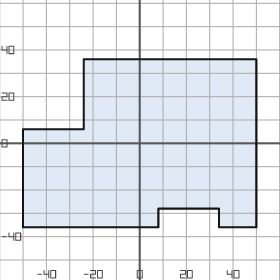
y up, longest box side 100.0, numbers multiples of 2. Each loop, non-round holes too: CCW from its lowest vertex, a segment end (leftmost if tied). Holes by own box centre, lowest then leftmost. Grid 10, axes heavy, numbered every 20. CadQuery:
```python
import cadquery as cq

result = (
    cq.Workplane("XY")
    .moveTo(-50.0, -36.0)
    .lineTo(8.0, -36.0)
    .lineTo(8.0, -28.0)
    .lineTo(34.0, -28.0)
    .lineTo(34.0, -36.0)
    .lineTo(50.0, -36.0)
    .lineTo(50.0, 36.0)
    .lineTo(-24.0, 36.0)
    .lineTo(-24.0, 6.0)
    .lineTo(-50.0, 6.0)
    .close()
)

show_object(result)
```